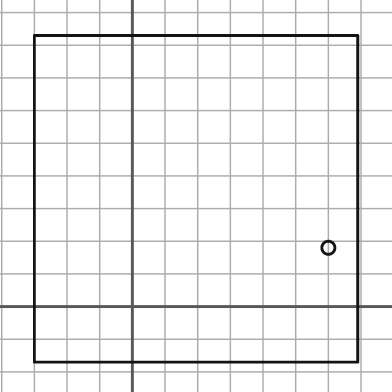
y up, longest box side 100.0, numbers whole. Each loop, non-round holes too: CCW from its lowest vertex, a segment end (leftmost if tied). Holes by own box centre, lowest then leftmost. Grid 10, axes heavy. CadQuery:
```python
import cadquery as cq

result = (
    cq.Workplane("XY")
    .moveTo(-30.0, -17.0)
    .lineTo(69.0, -17.0)
    .lineTo(69.0, 83.0)
    .lineTo(-30.0, 83.0)
    .close()
    .moveTo(60.0, 18.0)
    .circle(2.0)
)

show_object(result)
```